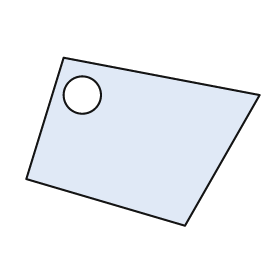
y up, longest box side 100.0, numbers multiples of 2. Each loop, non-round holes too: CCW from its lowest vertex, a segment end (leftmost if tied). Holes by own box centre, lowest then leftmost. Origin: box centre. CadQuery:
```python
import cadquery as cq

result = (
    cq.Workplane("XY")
    .moveTo(18.0, -36.0)
    .lineTo(50.0, 20.0)
    .lineTo(-34.0, 36.0)
    .lineTo(-50.0, -16.0)
    .close()
    .moveTo(-26.0, 20.0)
    .circle(8.0)
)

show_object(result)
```